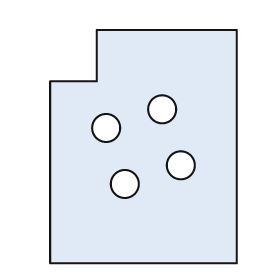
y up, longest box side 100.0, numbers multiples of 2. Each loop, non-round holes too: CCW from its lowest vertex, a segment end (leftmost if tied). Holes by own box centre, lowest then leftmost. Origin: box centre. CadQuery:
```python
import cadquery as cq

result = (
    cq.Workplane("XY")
    .moveTo(-40.0, -50.0)
    .lineTo(40.0, -50.0)
    .lineTo(40.0, 50.0)
    .lineTo(-20.0, 50.0)
    .lineTo(-20.0, 28.0)
    .lineTo(-40.0, 28.0)
    .close()
    .moveTo(-8.0, -16.0)
    .circle(6.0)
    .moveTo(16.0, -8.0)
    .circle(6.0)
    .moveTo(-16.0, 8.0)
    .circle(6.0)
    .moveTo(8.0, 16.0)
    .circle(6.0)
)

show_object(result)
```